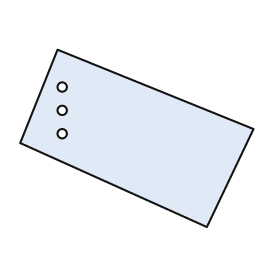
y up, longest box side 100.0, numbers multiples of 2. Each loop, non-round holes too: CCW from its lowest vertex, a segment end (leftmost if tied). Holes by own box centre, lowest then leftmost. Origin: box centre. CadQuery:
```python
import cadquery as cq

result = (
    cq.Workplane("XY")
    .moveTo(30.0, -38.0)
    .lineTo(50.0, 4.0)
    .lineTo(-34.0, 38.0)
    .lineTo(-50.0, -2.0)
    .close()
    .moveTo(-32.0, 2.0)
    .circle(2.0)
    .moveTo(-32.0, 12.0)
    .circle(2.0)
    .moveTo(-32.0, 22.0)
    .circle(2.0)
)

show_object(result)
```